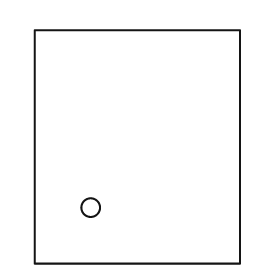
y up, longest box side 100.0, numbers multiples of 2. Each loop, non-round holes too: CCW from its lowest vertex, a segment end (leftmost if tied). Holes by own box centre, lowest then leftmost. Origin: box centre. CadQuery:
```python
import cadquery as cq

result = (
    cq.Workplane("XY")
    .moveTo(-44.0, -50.0)
    .lineTo(44.0, -50.0)
    .lineTo(44.0, 50.0)
    .lineTo(-44.0, 50.0)
    .close()
    .moveTo(-20.0, -26.0)
    .circle(4.0)
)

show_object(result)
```